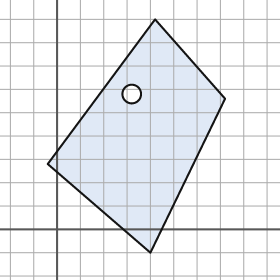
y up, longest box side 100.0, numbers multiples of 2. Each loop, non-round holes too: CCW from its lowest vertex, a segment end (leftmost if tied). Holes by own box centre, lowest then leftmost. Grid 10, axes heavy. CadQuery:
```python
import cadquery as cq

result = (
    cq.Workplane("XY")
    .moveTo(40.0, -10.0)
    .lineTo(72.0, 56.0)
    .lineTo(42.0, 90.0)
    .lineTo(-4.0, 28.0)
    .close()
    .moveTo(32.0, 58.0)
    .circle(4.0)
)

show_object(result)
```